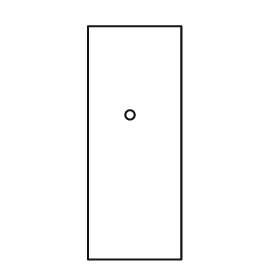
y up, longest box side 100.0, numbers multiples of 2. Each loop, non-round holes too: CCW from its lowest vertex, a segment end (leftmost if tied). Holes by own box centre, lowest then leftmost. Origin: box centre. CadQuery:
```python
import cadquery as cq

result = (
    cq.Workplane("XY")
    .moveTo(-20.0, -50.0)
    .lineTo(20.0, -50.0)
    .lineTo(20.0, 50.0)
    .lineTo(-20.0, 50.0)
    .close()
    .moveTo(-2.0, 12.0)
    .circle(2.0)
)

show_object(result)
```